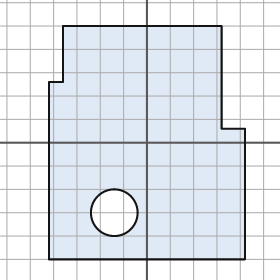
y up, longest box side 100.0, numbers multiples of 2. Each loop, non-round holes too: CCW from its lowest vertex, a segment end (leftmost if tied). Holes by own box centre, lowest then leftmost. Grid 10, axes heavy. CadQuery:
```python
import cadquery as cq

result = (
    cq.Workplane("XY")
    .moveTo(-42.0, -50.0)
    .lineTo(42.0, -50.0)
    .lineTo(42.0, 6.0)
    .lineTo(32.0, 6.0)
    .lineTo(32.0, 50.0)
    .lineTo(-36.0, 50.0)
    .lineTo(-36.0, 26.0)
    .lineTo(-42.0, 26.0)
    .close()
    .moveTo(-14.0, -30.0)
    .circle(10.0)
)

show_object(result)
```